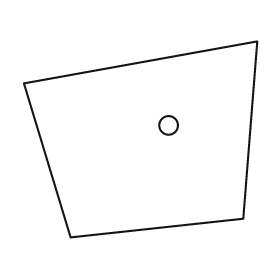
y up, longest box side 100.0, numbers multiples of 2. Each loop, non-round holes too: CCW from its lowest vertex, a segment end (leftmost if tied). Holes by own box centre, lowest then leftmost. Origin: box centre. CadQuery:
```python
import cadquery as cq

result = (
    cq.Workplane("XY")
    .moveTo(-30.0, -42.0)
    .lineTo(44.0, -34.0)
    .lineTo(50.0, 42.0)
    .lineTo(-50.0, 24.0)
    .close()
    .moveTo(12.0, 6.0)
    .circle(4.0)
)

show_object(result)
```